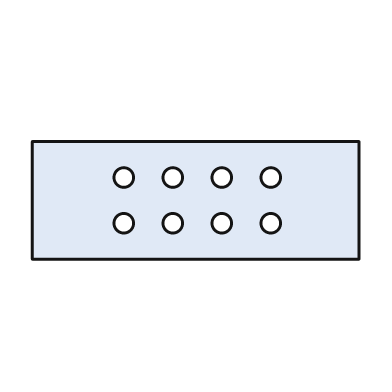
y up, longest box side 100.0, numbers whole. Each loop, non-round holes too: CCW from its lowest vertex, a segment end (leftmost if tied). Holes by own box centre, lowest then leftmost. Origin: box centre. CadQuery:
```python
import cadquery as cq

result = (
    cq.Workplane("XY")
    .moveTo(-50.0, -18.0)
    .lineTo(50.0, -18.0)
    .lineTo(50.0, 18.0)
    .lineTo(-50.0, 18.0)
    .close()
    .moveTo(-22.0, -7.0)
    .circle(3.0)
    .moveTo(-7.0, -7.0)
    .circle(3.0)
    .moveTo(8.0, -7.0)
    .circle(3.0)
    .moveTo(23.0, -7.0)
    .circle(3.0)
    .moveTo(-22.0, 7.0)
    .circle(3.0)
    .moveTo(-7.0, 7.0)
    .circle(3.0)
    .moveTo(8.0, 7.0)
    .circle(3.0)
    .moveTo(23.0, 7.0)
    .circle(3.0)
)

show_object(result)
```